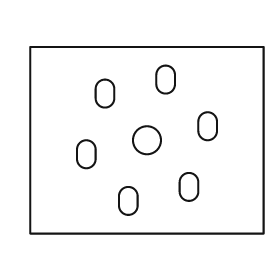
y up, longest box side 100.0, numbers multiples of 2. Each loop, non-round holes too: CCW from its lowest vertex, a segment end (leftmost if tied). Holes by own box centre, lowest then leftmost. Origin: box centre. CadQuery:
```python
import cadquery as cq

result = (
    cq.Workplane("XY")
    .moveTo(-50.0, -40.0)
    .lineTo(50.0, -40.0)
    .lineTo(50.0, 40.0)
    .lineTo(-50.0, 40.0)
    .close()
    .moveTo(-12.0, -28.0)
    .threePointArc((-8.0, -32.0), (-4.0, -28.0))
    .lineTo(-4.0, -24.0)
    .threePointArc((-8.0, -20.0), (-12.0, -24.0))
    .close()
    .moveTo(14.0, -22.0)
    .threePointArc((18.0, -26.0), (22.0, -22.0))
    .lineTo(22.0, -18.0)
    .threePointArc((18.0, -14.0), (14.0, -18.0))
    .close()
    .moveTo(-30.0, -8.0)
    .threePointArc((-26.0, -12.0), (-22.0, -8.0))
    .lineTo(-22.0, -4.0)
    .threePointArc((-26.0, 0.0), (-30.0, -4.0))
    .close()
    .moveTo(0.0, 0.0)
    .circle(6.0)
    .moveTo(22.0, 4.0)
    .threePointArc((26.0, 0.0), (30.0, 4.0))
    .lineTo(30.0, 8.0)
    .threePointArc((26.0, 12.0), (22.0, 8.0))
    .close()
    .moveTo(-22.0, 18.0)
    .threePointArc((-18.0, 14.0), (-14.0, 18.0))
    .lineTo(-14.0, 22.0)
    .threePointArc((-18.0, 26.0), (-22.0, 22.0))
    .close()
    .moveTo(4.0, 24.0)
    .threePointArc((8.0, 20.0), (12.0, 24.0))
    .lineTo(12.0, 28.0)
    .threePointArc((8.0, 32.0), (4.0, 28.0))
    .close()
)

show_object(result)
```